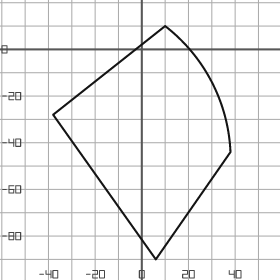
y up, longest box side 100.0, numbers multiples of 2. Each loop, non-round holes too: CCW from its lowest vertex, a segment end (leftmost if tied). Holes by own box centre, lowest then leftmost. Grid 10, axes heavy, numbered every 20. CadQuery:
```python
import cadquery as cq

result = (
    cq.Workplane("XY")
    .moveTo(6.0, -90.0)
    .lineTo(38.0, -44.0)
    .threePointArc((30.0, -14.0), (10.0, 10.0))
    .lineTo(-38.0, -28.0)
    .close()
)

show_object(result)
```